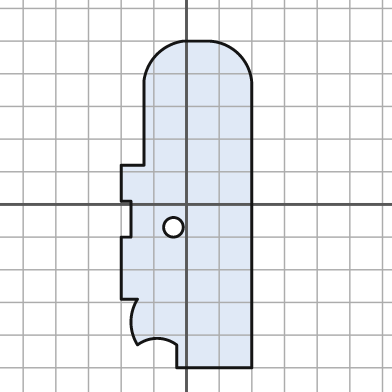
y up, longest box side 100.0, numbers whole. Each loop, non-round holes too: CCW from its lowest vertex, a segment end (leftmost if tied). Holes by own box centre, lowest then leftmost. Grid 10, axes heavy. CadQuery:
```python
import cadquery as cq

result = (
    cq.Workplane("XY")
    .moveTo(-3.0, -50.0)
    .lineTo(20.0, -50.0)
    .lineTo(20.0, 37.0)
    .threePointArc((16.0, 46.0), (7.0, 50.0))
    .lineTo(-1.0, 50.0)
    .threePointArc((-9.0, 46.0), (-13.0, 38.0))
    .lineTo(-13.0, 12.0)
    .lineTo(-20.0, 12.0)
    .lineTo(-20.0, 1.0)
    .lineTo(-17.0, 1.0)
    .lineTo(-17.0, -10.0)
    .lineTo(-20.0, -10.0)
    .lineTo(-20.0, -29.0)
    .lineTo(-15.0, -29.0)
    .threePointArc((-17.0, -36.0), (-15.0, -43.0))
    .threePointArc((-9.0, -41.0), (-3.0, -43.0))
    .close()
    .moveTo(-4.0, -7.0)
    .circle(3.0)
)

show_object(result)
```